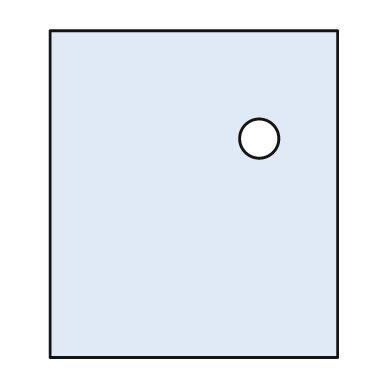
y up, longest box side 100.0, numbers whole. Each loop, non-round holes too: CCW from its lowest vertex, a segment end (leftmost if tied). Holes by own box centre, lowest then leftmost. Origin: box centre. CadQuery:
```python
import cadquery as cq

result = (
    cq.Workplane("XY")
    .moveTo(-44.0, -50.0)
    .lineTo(44.0, -50.0)
    .lineTo(44.0, 50.0)
    .lineTo(-44.0, 50.0)
    .close()
    .moveTo(20.0, 17.0)
    .circle(6.0)
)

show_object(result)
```